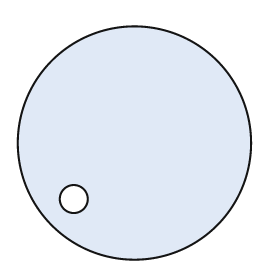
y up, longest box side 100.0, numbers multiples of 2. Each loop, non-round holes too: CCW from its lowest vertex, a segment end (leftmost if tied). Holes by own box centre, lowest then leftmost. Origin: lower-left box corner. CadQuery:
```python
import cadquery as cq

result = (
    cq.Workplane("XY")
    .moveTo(50.0, 50.0)
    .circle(50.0)
    .moveTo(24.0, 26.0)
    .circle(6.0)
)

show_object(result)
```